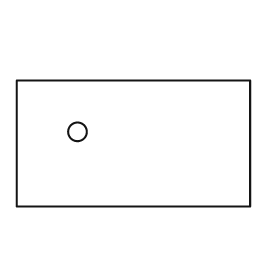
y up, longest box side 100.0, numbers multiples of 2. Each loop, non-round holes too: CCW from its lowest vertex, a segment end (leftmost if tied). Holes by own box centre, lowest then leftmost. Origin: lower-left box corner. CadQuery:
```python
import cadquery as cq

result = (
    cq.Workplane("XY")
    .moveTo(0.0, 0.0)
    .lineTo(100.0, 0.0)
    .lineTo(100.0, 54.0)
    .lineTo(0.0, 54.0)
    .close()
    .moveTo(26.0, 32.0)
    .circle(4.0)
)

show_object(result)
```